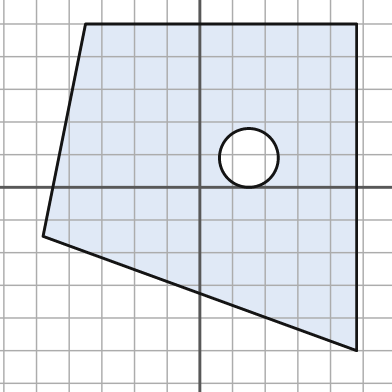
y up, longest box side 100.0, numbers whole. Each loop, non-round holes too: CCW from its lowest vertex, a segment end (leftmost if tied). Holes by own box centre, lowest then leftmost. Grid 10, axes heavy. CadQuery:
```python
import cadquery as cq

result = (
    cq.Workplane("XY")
    .moveTo(48.0, -50.0)
    .lineTo(48.0, 50.0)
    .lineTo(-35.0, 50.0)
    .lineTo(-48.0, -15.0)
    .close()
    .moveTo(15.0, 9.0)
    .circle(9.0)
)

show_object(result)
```